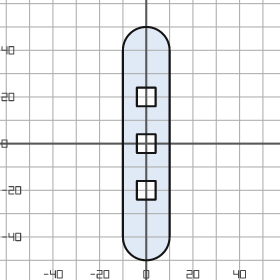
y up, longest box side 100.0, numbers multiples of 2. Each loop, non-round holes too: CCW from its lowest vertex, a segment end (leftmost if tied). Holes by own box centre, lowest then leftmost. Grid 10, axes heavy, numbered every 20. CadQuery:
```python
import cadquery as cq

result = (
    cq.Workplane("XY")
    .moveTo(-10.0, -40.0)
    .threePointArc((0.0, -50.0), (10.0, -40.0))
    .lineTo(10.0, 40.0)
    .threePointArc((0.0, 50.0), (-10.0, 40.0))
    .close()
    .moveTo(-4.0, -24.0)
    .lineTo(4.0, -24.0)
    .lineTo(4.0, -16.0)
    .lineTo(-4.0, -16.0)
    .close()
    .moveTo(-4.0, -4.0)
    .lineTo(4.0, -4.0)
    .lineTo(4.0, 4.0)
    .lineTo(-4.0, 4.0)
    .close()
    .moveTo(-4.0, 16.0)
    .lineTo(4.0, 16.0)
    .lineTo(4.0, 24.0)
    .lineTo(-4.0, 24.0)
    .close()
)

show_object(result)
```